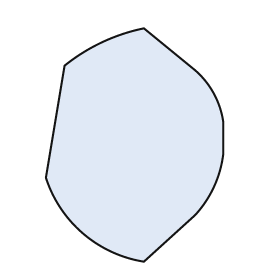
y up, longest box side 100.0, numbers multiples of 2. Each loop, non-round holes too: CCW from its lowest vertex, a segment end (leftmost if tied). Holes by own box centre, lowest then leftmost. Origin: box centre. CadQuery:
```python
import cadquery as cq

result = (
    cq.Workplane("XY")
    .moveTo(4.0, -50.0)
    .lineTo(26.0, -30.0)
    .threePointArc((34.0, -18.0), (38.0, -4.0))
    .lineTo(38.0, 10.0)
    .threePointArc((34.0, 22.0), (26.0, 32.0))
    .lineTo(4.0, 50.0)
    .threePointArc((-14.0, 44.0), (-30.0, 34.0))
    .lineTo(-38.0, -14.0)
    .threePointArc((-22.0, -38.0), (4.0, -50.0))
    .close()
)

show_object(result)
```